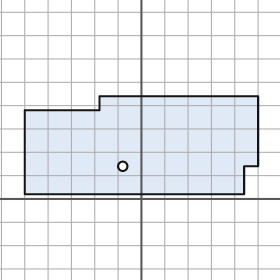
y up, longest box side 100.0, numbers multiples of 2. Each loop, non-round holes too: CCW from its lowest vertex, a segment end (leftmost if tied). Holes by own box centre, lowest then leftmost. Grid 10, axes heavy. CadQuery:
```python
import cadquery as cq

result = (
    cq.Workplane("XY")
    .moveTo(-50.0, 2.0)
    .lineTo(44.0, 2.0)
    .lineTo(44.0, 14.0)
    .lineTo(50.0, 14.0)
    .lineTo(50.0, 44.0)
    .lineTo(-18.0, 44.0)
    .lineTo(-18.0, 38.0)
    .lineTo(-50.0, 38.0)
    .close()
    .moveTo(-8.0, 14.0)
    .circle(2.0)
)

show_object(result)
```